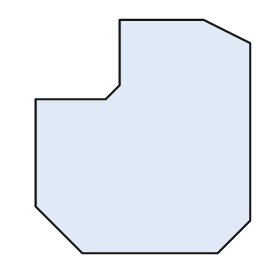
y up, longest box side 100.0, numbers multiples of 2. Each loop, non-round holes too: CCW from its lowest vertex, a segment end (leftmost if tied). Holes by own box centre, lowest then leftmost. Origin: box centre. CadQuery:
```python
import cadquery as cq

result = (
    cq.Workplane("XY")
    .moveTo(-26.0, -50.0)
    .lineTo(32.0, -50.0)
    .lineTo(46.0, -36.0)
    .lineTo(46.0, 40.0)
    .lineTo(26.0, 50.0)
    .lineTo(-10.0, 50.0)
    .lineTo(-10.0, 22.0)
    .lineTo(-16.0, 16.0)
    .lineTo(-46.0, 16.0)
    .lineTo(-46.0, -30.0)
    .close()
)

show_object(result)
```